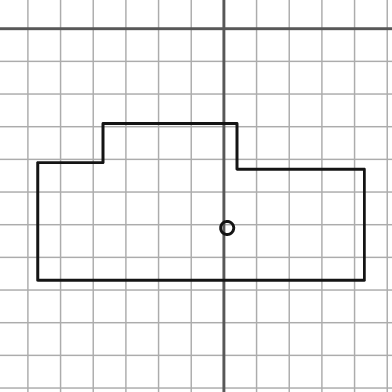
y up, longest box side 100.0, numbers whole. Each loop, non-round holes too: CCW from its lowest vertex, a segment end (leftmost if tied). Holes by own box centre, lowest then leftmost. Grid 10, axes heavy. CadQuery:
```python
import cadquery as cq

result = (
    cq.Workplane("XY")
    .moveTo(-57.0, -77.0)
    .lineTo(43.0, -77.0)
    .lineTo(43.0, -43.0)
    .lineTo(4.0, -43.0)
    .lineTo(4.0, -29.0)
    .lineTo(-37.0, -29.0)
    .lineTo(-37.0, -41.0)
    .lineTo(-57.0, -41.0)
    .close()
    .moveTo(1.0, -61.0)
    .circle(2.0)
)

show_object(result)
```